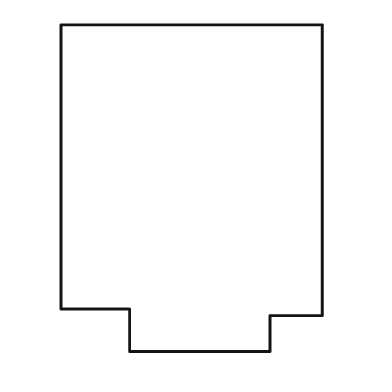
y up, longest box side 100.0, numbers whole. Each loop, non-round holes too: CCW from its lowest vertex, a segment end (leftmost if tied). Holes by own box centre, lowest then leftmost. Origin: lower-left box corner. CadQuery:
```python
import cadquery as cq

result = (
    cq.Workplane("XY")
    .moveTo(21.0, 0.0)
    .lineTo(64.0, 0.0)
    .lineTo(64.0, 11.0)
    .lineTo(80.0, 11.0)
    .lineTo(80.0, 100.0)
    .lineTo(0.0, 100.0)
    .lineTo(0.0, 13.0)
    .lineTo(21.0, 13.0)
    .close()
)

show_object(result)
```